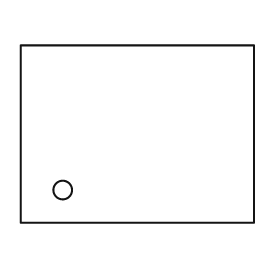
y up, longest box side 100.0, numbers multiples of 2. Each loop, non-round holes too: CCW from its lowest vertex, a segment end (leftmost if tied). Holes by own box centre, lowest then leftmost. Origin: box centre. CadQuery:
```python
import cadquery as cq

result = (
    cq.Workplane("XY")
    .moveTo(-50.0, -38.0)
    .lineTo(50.0, -38.0)
    .lineTo(50.0, 38.0)
    .lineTo(-50.0, 38.0)
    .close()
    .moveTo(-32.0, -24.0)
    .circle(4.0)
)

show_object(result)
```